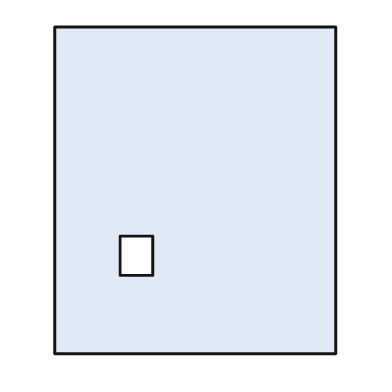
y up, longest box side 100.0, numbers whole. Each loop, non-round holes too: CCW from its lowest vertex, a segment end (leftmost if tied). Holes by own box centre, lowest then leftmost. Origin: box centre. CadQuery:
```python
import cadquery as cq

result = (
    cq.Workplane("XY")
    .moveTo(-43.0, -50.0)
    .lineTo(43.0, -50.0)
    .lineTo(43.0, 50.0)
    .lineTo(-43.0, 50.0)
    .close()
    .moveTo(-23.0, -26.0)
    .lineTo(-13.0, -26.0)
    .lineTo(-13.0, -14.0)
    .lineTo(-23.0, -14.0)
    .close()
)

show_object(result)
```